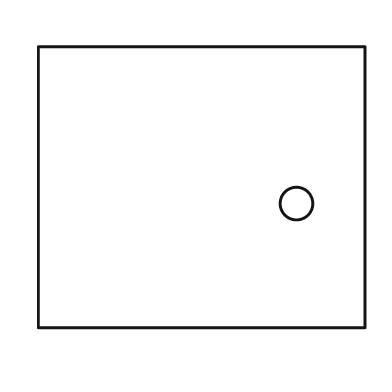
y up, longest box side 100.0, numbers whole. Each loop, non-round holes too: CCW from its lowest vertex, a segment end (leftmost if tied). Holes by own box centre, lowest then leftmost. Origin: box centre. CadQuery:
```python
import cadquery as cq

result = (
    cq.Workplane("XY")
    .moveTo(-50.0, -43.0)
    .lineTo(50.0, -43.0)
    .lineTo(50.0, 43.0)
    .lineTo(-50.0, 43.0)
    .close()
    .moveTo(29.0, -5.0)
    .circle(5.0)
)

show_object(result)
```